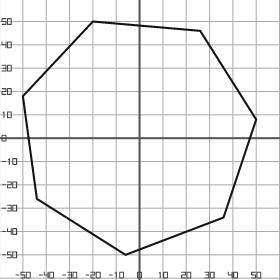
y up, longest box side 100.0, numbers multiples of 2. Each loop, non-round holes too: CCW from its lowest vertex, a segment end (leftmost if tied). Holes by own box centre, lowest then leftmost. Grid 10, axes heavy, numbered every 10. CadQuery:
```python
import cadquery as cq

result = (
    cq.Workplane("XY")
    .moveTo(-6.0, -50.0)
    .lineTo(36.0, -34.0)
    .lineTo(50.0, 8.0)
    .lineTo(26.0, 46.0)
    .lineTo(-20.0, 50.0)
    .lineTo(-50.0, 18.0)
    .lineTo(-44.0, -26.0)
    .close()
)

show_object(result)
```